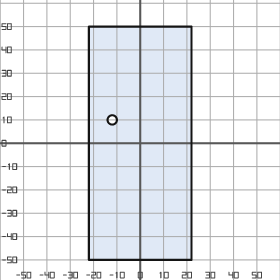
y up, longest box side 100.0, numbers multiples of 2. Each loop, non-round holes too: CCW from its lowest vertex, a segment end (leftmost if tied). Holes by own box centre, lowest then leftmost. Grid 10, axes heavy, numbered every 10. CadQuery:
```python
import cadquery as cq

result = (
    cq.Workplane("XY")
    .moveTo(-22.0, -50.0)
    .lineTo(22.0, -50.0)
    .lineTo(22.0, 50.0)
    .lineTo(-22.0, 50.0)
    .close()
    .moveTo(-12.0, 10.0)
    .circle(2.0)
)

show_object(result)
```